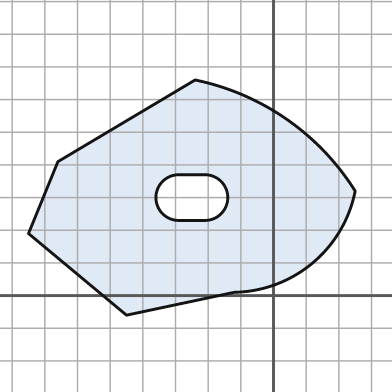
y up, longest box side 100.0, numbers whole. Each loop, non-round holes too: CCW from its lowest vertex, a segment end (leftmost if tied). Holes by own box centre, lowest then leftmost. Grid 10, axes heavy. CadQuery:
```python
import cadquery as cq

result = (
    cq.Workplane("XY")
    .moveTo(-45.0, -6.0)
    .lineTo(-12.0, 1.0)
    .threePointArc((12.0, 10.0), (25.0, 32.0))
    .threePointArc((4.0, 54.0), (-24.0, 66.0))
    .lineTo(-66.0, 41.0)
    .lineTo(-75.0, 19.0)
    .close()
    .moveTo(-29.0, 23.0)
    .lineTo(-21.0, 23.0)
    .threePointArc((-14.0, 30.0), (-21.0, 37.0))
    .lineTo(-29.0, 37.0)
    .threePointArc((-36.0, 30.0), (-29.0, 23.0))
    .close()
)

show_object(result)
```